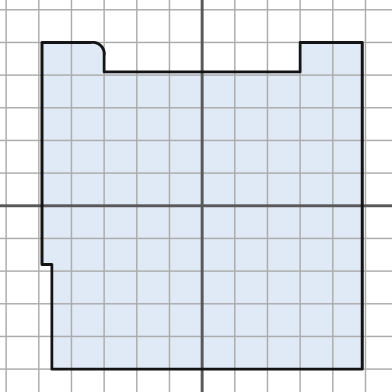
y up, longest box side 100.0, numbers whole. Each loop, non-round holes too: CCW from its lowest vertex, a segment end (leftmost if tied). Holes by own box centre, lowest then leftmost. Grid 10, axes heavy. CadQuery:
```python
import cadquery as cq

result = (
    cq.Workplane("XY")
    .moveTo(-46.0, -50.0)
    .lineTo(49.0, -50.0)
    .lineTo(49.0, 50.0)
    .lineTo(30.0, 50.0)
    .lineTo(30.0, 41.0)
    .lineTo(-30.0, 41.0)
    .lineTo(-30.0, 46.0)
    .threePointArc((-31.0, 49.0), (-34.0, 50.0))
    .lineTo(-49.0, 50.0)
    .lineTo(-49.0, -18.0)
    .lineTo(-46.0, -18.0)
    .close()
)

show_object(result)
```